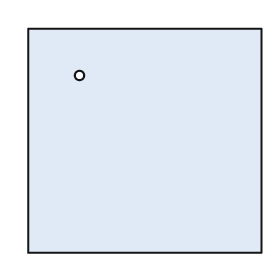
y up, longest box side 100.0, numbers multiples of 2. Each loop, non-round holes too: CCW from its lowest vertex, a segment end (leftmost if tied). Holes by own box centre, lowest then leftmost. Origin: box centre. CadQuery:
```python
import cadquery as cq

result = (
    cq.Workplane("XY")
    .moveTo(-50.0, -48.0)
    .lineTo(50.0, -48.0)
    .lineTo(50.0, 48.0)
    .lineTo(-50.0, 48.0)
    .close()
    .moveTo(-28.0, 28.0)
    .circle(2.0)
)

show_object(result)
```